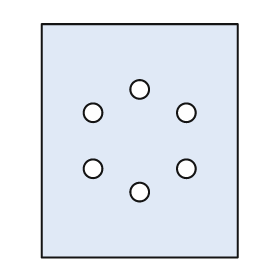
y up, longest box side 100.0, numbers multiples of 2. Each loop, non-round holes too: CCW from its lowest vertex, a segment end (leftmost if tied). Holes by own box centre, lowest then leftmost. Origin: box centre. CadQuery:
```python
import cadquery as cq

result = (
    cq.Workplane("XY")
    .moveTo(-42.0, -50.0)
    .lineTo(42.0, -50.0)
    .lineTo(42.0, 50.0)
    .lineTo(-42.0, 50.0)
    .close()
    .moveTo(0.0, -22.0)
    .circle(4.0)
    .moveTo(-20.0, -12.0)
    .circle(4.0)
    .moveTo(20.0, -12.0)
    .circle(4.0)
    .moveTo(-20.0, 12.0)
    .circle(4.0)
    .moveTo(20.0, 12.0)
    .circle(4.0)
    .moveTo(0.0, 22.0)
    .circle(4.0)
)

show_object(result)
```